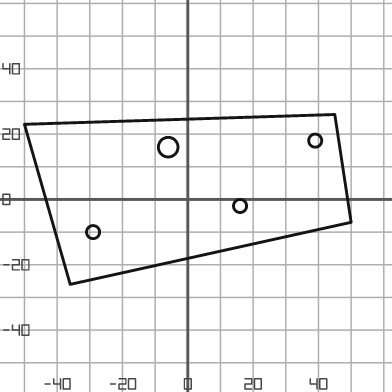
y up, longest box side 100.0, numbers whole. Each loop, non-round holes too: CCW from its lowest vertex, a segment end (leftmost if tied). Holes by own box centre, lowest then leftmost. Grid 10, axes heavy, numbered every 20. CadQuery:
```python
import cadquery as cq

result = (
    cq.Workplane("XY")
    .moveTo(-36.0, -26.0)
    .lineTo(50.0, -7.0)
    .lineTo(45.0, 26.0)
    .lineTo(-50.0, 23.0)
    .close()
    .moveTo(-29.0, -10.0)
    .circle(2.0)
    .moveTo(16.0, -2.0)
    .circle(2.0)
    .moveTo(-6.0, 16.0)
    .circle(3.0)
    .moveTo(39.0, 18.0)
    .circle(2.0)
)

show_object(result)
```